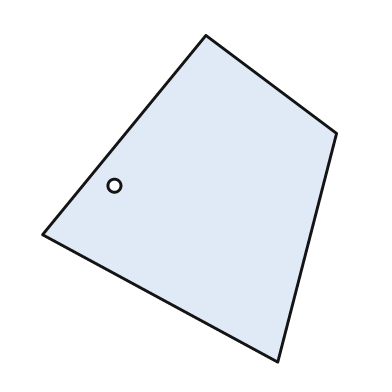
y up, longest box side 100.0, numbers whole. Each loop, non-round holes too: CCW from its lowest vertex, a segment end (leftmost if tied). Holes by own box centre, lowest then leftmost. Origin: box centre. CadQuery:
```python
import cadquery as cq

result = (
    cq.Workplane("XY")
    .moveTo(27.0, -50.0)
    .lineTo(45.0, 20.0)
    .lineTo(5.0, 50.0)
    .lineTo(-45.0, -11.0)
    .close()
    .moveTo(-23.0, 4.0)
    .circle(2.0)
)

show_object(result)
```